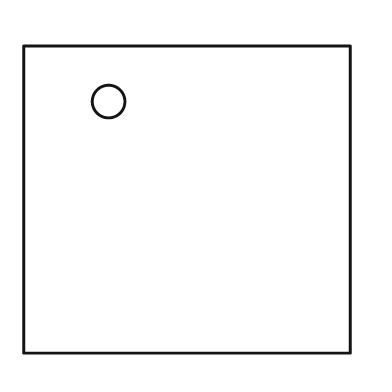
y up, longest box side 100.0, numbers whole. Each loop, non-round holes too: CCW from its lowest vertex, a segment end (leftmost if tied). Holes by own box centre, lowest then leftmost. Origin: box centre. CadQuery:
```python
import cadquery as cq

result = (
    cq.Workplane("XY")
    .moveTo(-50.0, -47.0)
    .lineTo(50.0, -47.0)
    .lineTo(50.0, 47.0)
    .lineTo(-50.0, 47.0)
    .close()
    .moveTo(-24.0, 30.0)
    .circle(5.0)
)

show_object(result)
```